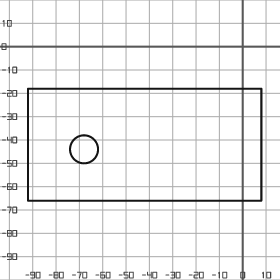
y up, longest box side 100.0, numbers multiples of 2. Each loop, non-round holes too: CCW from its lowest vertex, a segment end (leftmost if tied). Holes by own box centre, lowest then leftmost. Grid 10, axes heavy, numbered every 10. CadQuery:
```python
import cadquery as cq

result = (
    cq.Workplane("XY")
    .moveTo(-92.0, -66.0)
    .lineTo(8.0, -66.0)
    .lineTo(8.0, -18.0)
    .lineTo(-92.0, -18.0)
    .close()
    .moveTo(-68.0, -44.0)
    .circle(6.0)
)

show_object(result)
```